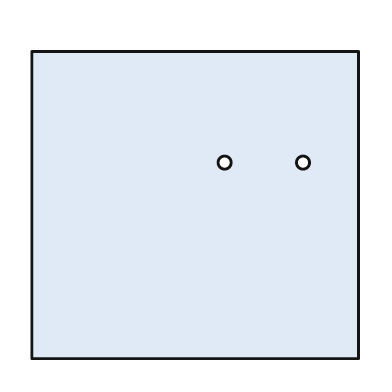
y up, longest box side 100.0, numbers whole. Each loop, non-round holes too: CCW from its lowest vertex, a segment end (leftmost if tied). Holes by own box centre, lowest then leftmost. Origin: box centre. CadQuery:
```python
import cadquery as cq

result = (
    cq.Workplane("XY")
    .moveTo(-50.0, -47.0)
    .lineTo(50.0, -47.0)
    .lineTo(50.0, 47.0)
    .lineTo(-50.0, 47.0)
    .close()
    .moveTo(9.0, 13.0)
    .circle(2.0)
    .moveTo(33.0, 13.0)
    .circle(2.0)
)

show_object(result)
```